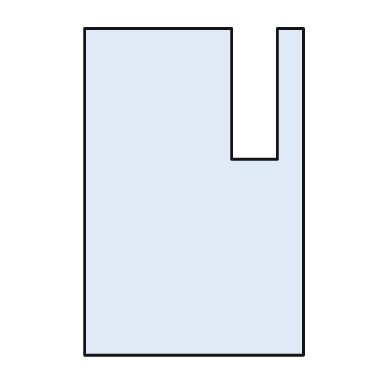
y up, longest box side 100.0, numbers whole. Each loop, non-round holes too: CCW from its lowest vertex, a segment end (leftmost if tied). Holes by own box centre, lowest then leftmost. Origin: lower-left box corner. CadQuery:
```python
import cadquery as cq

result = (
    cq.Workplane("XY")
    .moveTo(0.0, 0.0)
    .lineTo(67.0, 0.0)
    .lineTo(67.0, 100.0)
    .lineTo(59.0, 100.0)
    .lineTo(59.0, 60.0)
    .lineTo(45.0, 60.0)
    .lineTo(45.0, 100.0)
    .lineTo(0.0, 100.0)
    .close()
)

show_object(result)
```